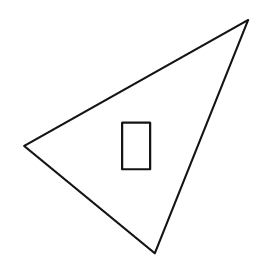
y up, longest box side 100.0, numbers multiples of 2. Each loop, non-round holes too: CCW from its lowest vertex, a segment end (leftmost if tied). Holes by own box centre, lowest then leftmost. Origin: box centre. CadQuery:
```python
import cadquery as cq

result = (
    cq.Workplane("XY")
    .moveTo(8.0, -50.0)
    .lineTo(48.0, 50.0)
    .lineTo(-48.0, -4.0)
    .close()
    .moveTo(-6.0, -14.0)
    .lineTo(6.0, -14.0)
    .lineTo(6.0, 6.0)
    .lineTo(-6.0, 6.0)
    .close()
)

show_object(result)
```